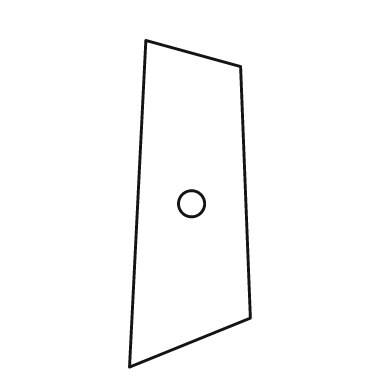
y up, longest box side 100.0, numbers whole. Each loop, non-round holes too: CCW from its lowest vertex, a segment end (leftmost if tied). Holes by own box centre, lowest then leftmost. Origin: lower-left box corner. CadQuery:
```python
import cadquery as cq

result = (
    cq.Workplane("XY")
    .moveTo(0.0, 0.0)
    .lineTo(37.0, 15.0)
    .lineTo(34.0, 92.0)
    .lineTo(5.0, 100.0)
    .close()
    .moveTo(19.0, 50.0)
    .circle(4.0)
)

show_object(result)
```